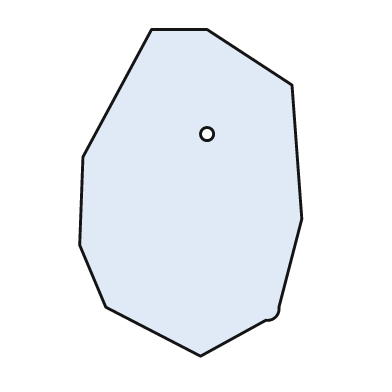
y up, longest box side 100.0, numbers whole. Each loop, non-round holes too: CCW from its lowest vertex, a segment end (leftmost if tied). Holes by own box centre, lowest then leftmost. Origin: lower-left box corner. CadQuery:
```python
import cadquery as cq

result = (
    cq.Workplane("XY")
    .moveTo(37.0, 0.0)
    .lineTo(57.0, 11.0)
    .threePointArc((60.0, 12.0), (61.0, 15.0))
    .lineTo(68.0, 42.0)
    .lineTo(65.0, 83.0)
    .lineTo(39.0, 100.0)
    .lineTo(22.0, 100.0)
    .lineTo(1.0, 61.0)
    .lineTo(0.0, 34.0)
    .lineTo(8.0, 15.0)
    .close()
    .moveTo(39.0, 68.0)
    .circle(2.0)
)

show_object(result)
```